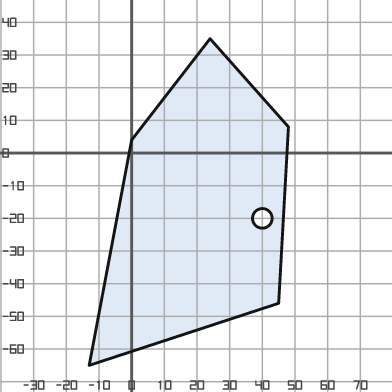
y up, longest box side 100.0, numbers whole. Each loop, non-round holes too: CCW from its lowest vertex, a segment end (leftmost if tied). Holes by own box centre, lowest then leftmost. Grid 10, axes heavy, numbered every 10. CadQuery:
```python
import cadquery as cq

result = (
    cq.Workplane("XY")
    .moveTo(-13.0, -65.0)
    .lineTo(45.0, -46.0)
    .lineTo(48.0, 8.0)
    .lineTo(24.0, 35.0)
    .lineTo(0.0, 4.0)
    .close()
    .moveTo(40.0, -20.0)
    .circle(3.0)
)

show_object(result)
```